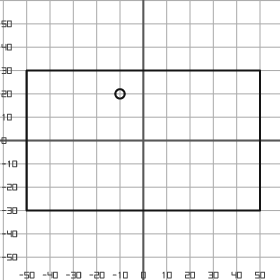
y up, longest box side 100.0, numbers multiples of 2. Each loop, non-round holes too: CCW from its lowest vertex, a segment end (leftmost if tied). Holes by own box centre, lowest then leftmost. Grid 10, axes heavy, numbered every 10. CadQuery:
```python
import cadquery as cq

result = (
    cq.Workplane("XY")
    .moveTo(-50.0, -30.0)
    .lineTo(50.0, -30.0)
    .lineTo(50.0, 30.0)
    .lineTo(-50.0, 30.0)
    .close()
    .moveTo(-10.0, 20.0)
    .circle(2.0)
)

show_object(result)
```